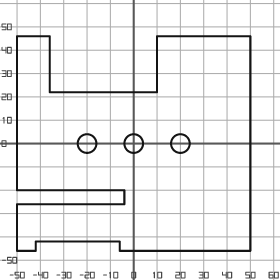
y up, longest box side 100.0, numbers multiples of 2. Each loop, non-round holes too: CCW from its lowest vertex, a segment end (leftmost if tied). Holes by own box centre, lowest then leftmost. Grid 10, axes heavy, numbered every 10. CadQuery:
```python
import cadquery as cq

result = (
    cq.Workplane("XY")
    .moveTo(-50.0, -46.0)
    .lineTo(-42.0, -46.0)
    .lineTo(-42.0, -42.0)
    .lineTo(-6.0, -42.0)
    .lineTo(-6.0, -46.0)
    .lineTo(50.0, -46.0)
    .lineTo(50.0, 46.0)
    .lineTo(10.0, 46.0)
    .lineTo(10.0, 22.0)
    .lineTo(-36.0, 22.0)
    .lineTo(-36.0, 46.0)
    .lineTo(-50.0, 46.0)
    .lineTo(-50.0, -20.0)
    .lineTo(-4.0, -20.0)
    .lineTo(-4.0, -26.0)
    .lineTo(-50.0, -26.0)
    .close()
    .moveTo(-20.0, 0.0)
    .circle(4.0)
    .moveTo(0.0, 0.0)
    .circle(4.0)
    .moveTo(20.0, 0.0)
    .circle(4.0)
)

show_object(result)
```